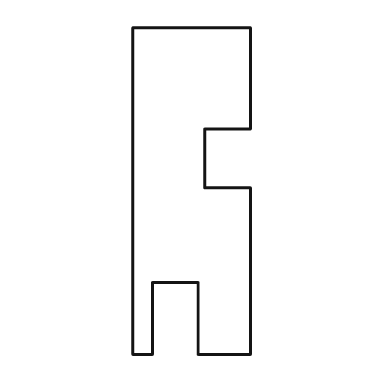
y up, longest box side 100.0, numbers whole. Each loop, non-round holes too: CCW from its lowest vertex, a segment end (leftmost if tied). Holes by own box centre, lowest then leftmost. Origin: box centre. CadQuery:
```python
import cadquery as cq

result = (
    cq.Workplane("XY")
    .moveTo(-18.0, -50.0)
    .lineTo(-12.0, -50.0)
    .lineTo(-12.0, -28.0)
    .lineTo(2.0, -28.0)
    .lineTo(2.0, -50.0)
    .lineTo(18.0, -50.0)
    .lineTo(18.0, 1.0)
    .lineTo(4.0, 1.0)
    .lineTo(4.0, 19.0)
    .lineTo(18.0, 19.0)
    .lineTo(18.0, 50.0)
    .lineTo(-18.0, 50.0)
    .close()
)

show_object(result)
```